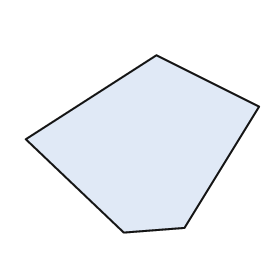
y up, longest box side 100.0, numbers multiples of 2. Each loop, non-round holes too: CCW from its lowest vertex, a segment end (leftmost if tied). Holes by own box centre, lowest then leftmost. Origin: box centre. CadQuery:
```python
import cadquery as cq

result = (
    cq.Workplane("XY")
    .moveTo(-8.0, -38.0)
    .lineTo(18.0, -36.0)
    .lineTo(50.0, 16.0)
    .lineTo(6.0, 38.0)
    .lineTo(-50.0, 2.0)
    .close()
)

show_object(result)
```